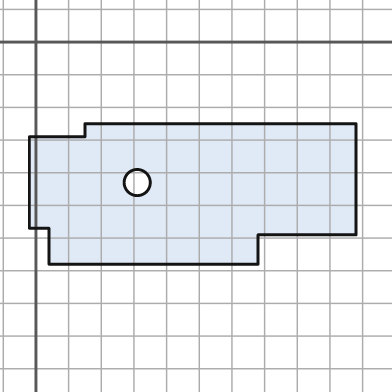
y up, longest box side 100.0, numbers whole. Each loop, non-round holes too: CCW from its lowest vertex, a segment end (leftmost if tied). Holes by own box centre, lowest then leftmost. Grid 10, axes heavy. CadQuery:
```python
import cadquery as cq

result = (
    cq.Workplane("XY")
    .moveTo(4.0, -68.0)
    .lineTo(68.0, -68.0)
    .lineTo(68.0, -59.0)
    .lineTo(98.0, -59.0)
    .lineTo(98.0, -25.0)
    .lineTo(15.0, -25.0)
    .lineTo(15.0, -29.0)
    .lineTo(-2.0, -29.0)
    .lineTo(-2.0, -57.0)
    .lineTo(4.0, -57.0)
    .close()
    .moveTo(31.0, -43.0)
    .circle(4.0)
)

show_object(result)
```